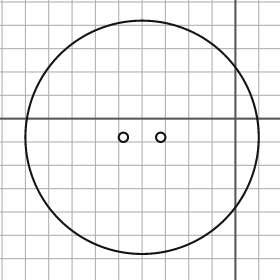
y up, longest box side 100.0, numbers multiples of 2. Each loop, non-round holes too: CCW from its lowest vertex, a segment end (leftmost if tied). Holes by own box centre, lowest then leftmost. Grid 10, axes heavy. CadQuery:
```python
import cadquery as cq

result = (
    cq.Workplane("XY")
    .moveTo(-40.0, -8.0)
    .circle(50.0)
    .moveTo(-48.0, -8.0)
    .circle(2.0)
    .moveTo(-32.0, -8.0)
    .circle(2.0)
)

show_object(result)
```